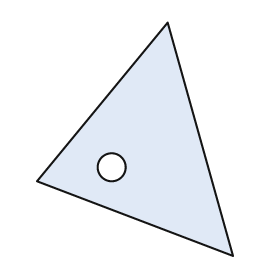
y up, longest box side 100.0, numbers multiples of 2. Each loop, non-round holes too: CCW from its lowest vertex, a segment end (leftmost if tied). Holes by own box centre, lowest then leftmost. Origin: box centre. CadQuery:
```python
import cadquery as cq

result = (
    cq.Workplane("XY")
    .moveTo(42.0, -50.0)
    .lineTo(14.0, 50.0)
    .lineTo(-42.0, -18.0)
    .close()
    .moveTo(-10.0, -12.0)
    .circle(6.0)
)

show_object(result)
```